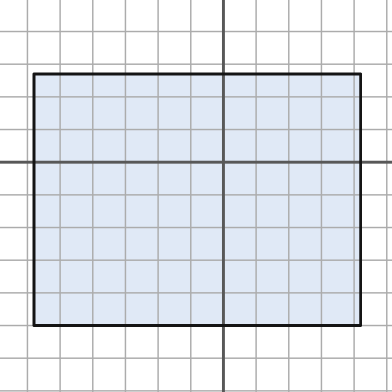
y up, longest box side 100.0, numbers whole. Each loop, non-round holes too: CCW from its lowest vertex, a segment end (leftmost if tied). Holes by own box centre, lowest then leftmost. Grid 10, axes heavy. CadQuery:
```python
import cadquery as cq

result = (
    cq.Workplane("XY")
    .moveTo(-58.0, -50.0)
    .lineTo(42.0, -50.0)
    .lineTo(42.0, 27.0)
    .lineTo(-58.0, 27.0)
    .close()
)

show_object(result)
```